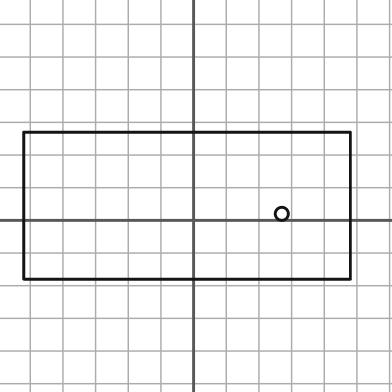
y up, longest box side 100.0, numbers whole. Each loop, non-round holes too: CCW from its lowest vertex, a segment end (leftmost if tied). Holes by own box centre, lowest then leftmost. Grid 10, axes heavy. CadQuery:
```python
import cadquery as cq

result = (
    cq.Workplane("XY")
    .moveTo(-52.0, -18.0)
    .lineTo(48.0, -18.0)
    .lineTo(48.0, 27.0)
    .lineTo(-52.0, 27.0)
    .close()
    .moveTo(27.0, 2.0)
    .circle(2.0)
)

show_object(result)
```